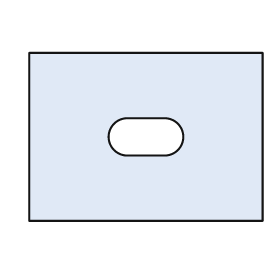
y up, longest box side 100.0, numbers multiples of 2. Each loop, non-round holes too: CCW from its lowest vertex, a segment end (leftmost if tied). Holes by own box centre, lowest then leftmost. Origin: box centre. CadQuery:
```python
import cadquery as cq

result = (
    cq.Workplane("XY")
    .moveTo(-50.0, -36.0)
    .lineTo(50.0, -36.0)
    .lineTo(50.0, 36.0)
    .lineTo(-50.0, 36.0)
    .close()
    .moveTo(-8.0, -8.0)
    .lineTo(8.0, -8.0)
    .threePointArc((16.0, 0.0), (8.0, 8.0))
    .lineTo(-8.0, 8.0)
    .threePointArc((-16.0, 0.0), (-8.0, -8.0))
    .close()
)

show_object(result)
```